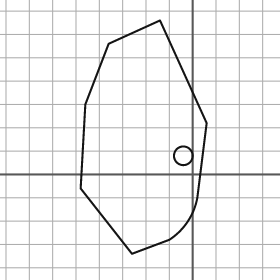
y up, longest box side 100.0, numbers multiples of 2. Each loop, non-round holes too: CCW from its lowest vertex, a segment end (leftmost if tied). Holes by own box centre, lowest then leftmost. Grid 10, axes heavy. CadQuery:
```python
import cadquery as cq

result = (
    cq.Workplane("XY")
    .moveTo(-26.0, -34.0)
    .lineTo(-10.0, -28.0)
    .threePointArc((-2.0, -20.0), (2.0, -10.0))
    .lineTo(6.0, 22.0)
    .lineTo(-14.0, 66.0)
    .lineTo(-36.0, 56.0)
    .lineTo(-46.0, 30.0)
    .lineTo(-48.0, -6.0)
    .close()
    .moveTo(-4.0, 8.0)
    .circle(4.0)
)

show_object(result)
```